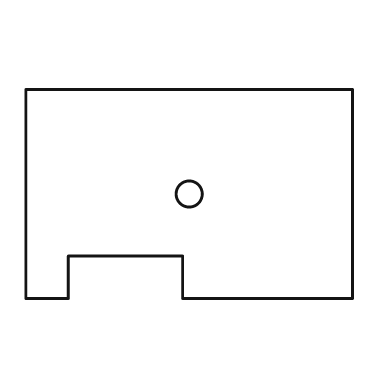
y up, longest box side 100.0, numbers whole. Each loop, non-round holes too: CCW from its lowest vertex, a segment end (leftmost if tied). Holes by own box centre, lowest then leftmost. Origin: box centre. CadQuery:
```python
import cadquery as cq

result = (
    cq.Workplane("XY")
    .moveTo(-50.0, -32.0)
    .lineTo(-37.0, -32.0)
    .lineTo(-37.0, -19.0)
    .lineTo(-2.0, -19.0)
    .lineTo(-2.0, -32.0)
    .lineTo(50.0, -32.0)
    .lineTo(50.0, 32.0)
    .lineTo(-50.0, 32.0)
    .close()
    .moveTo(0.0, 0.0)
    .circle(4.0)
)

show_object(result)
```